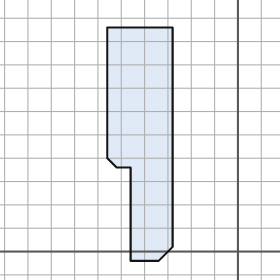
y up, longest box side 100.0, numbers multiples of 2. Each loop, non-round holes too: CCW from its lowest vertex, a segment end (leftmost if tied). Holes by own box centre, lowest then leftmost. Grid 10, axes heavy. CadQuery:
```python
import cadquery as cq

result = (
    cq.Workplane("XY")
    .moveTo(-46.0, -4.0)
    .lineTo(-34.0, -4.0)
    .lineTo(-28.0, 2.0)
    .lineTo(-28.0, 96.0)
    .lineTo(-56.0, 96.0)
    .lineTo(-56.0, 40.0)
    .lineTo(-52.0, 36.0)
    .lineTo(-46.0, 36.0)
    .close()
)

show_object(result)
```